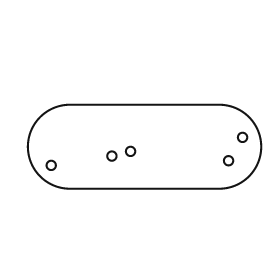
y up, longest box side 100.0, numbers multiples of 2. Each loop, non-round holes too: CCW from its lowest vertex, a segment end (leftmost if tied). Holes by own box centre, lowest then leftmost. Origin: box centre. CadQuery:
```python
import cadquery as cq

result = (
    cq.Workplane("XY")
    .moveTo(-32.0, -18.0)
    .lineTo(32.0, -18.0)
    .threePointArc((50.0, 0.0), (32.0, 18.0))
    .lineTo(-32.0, 18.0)
    .threePointArc((-50.0, 0.0), (-32.0, -18.0))
    .close()
    .moveTo(-40.0, -8.0)
    .circle(2.0)
    .moveTo(36.0, -6.0)
    .circle(2.0)
    .moveTo(-14.0, -4.0)
    .circle(2.0)
    .moveTo(-6.0, -2.0)
    .circle(2.0)
    .moveTo(42.0, 4.0)
    .circle(2.0)
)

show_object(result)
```